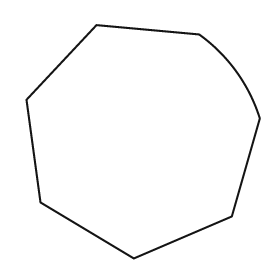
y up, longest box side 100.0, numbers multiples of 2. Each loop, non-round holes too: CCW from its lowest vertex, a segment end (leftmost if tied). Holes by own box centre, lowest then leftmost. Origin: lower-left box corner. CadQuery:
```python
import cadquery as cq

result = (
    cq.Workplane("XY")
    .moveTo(46.0, 0.0)
    .lineTo(88.0, 18.0)
    .lineTo(100.0, 60.0)
    .threePointArc((90.0, 80.0), (74.0, 96.0))
    .lineTo(30.0, 100.0)
    .lineTo(0.0, 68.0)
    .lineTo(6.0, 24.0)
    .close()
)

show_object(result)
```